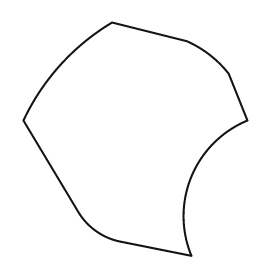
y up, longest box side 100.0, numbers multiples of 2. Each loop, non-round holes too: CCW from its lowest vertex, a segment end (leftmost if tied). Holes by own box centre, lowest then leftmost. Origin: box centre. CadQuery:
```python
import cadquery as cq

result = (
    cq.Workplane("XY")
    .moveTo(24.0, -50.0)
    .threePointArc((24.0, -16.0), (48.0, 8.0))
    .lineTo(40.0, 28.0)
    .threePointArc((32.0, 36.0), (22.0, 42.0))
    .lineTo(-10.0, 50.0)
    .threePointArc((-32.0, 32.0), (-48.0, 8.0))
    .lineTo(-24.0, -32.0)
    .threePointArc((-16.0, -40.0), (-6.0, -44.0))
    .close()
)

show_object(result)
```